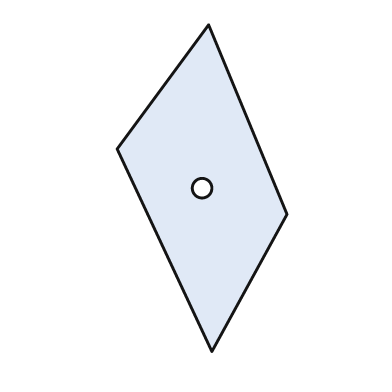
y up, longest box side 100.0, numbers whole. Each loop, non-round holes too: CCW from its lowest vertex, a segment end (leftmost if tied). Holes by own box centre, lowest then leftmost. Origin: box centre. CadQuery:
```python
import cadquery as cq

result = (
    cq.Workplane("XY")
    .moveTo(3.0, -50.0)
    .lineTo(26.0, -8.0)
    .lineTo(2.0, 50.0)
    .lineTo(-26.0, 12.0)
    .close()
    .moveTo(0.0, 0.0)
    .circle(3.0)
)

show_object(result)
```